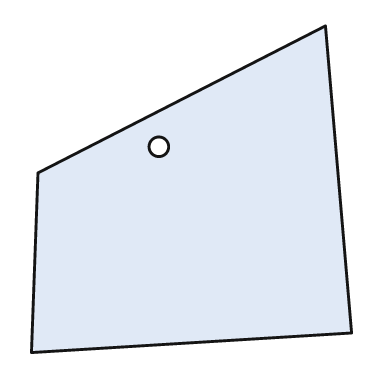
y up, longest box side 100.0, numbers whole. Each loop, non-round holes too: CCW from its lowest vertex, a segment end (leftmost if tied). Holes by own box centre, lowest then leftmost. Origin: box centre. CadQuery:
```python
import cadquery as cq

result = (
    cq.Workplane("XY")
    .moveTo(-49.0, -50.0)
    .lineTo(49.0, -44.0)
    .lineTo(41.0, 50.0)
    .lineTo(-47.0, 5.0)
    .close()
    .moveTo(-10.0, 13.0)
    .circle(3.0)
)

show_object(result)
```